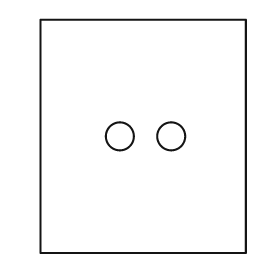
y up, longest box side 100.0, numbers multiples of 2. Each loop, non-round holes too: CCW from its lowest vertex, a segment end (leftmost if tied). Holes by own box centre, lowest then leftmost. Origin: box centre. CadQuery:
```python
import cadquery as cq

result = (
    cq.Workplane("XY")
    .moveTo(-44.0, -50.0)
    .lineTo(44.0, -50.0)
    .lineTo(44.0, 50.0)
    .lineTo(-44.0, 50.0)
    .close()
    .moveTo(-10.0, 0.0)
    .circle(6.0)
    .moveTo(12.0, 0.0)
    .circle(6.0)
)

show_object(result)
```